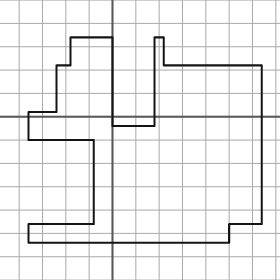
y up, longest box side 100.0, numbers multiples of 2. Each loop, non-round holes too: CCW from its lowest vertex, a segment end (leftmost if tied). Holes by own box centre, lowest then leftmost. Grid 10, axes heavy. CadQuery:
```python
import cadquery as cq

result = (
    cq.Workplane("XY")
    .moveTo(-36.0, -54.0)
    .lineTo(50.0, -54.0)
    .lineTo(50.0, -46.0)
    .lineTo(64.0, -46.0)
    .lineTo(64.0, 22.0)
    .lineTo(22.0, 22.0)
    .lineTo(22.0, 34.0)
    .lineTo(18.0, 34.0)
    .lineTo(18.0, -4.0)
    .lineTo(0.0, -4.0)
    .lineTo(0.0, 34.0)
    .lineTo(-18.0, 34.0)
    .lineTo(-18.0, 22.0)
    .lineTo(-24.0, 22.0)
    .lineTo(-24.0, 2.0)
    .lineTo(-36.0, 2.0)
    .lineTo(-36.0, -10.0)
    .lineTo(-8.0, -10.0)
    .lineTo(-8.0, -46.0)
    .lineTo(-36.0, -46.0)
    .close()
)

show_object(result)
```